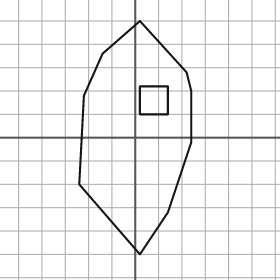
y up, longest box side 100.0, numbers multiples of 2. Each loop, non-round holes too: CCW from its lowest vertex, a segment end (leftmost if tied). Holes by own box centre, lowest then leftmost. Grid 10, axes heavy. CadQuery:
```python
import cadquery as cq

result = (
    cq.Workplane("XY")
    .moveTo(2.0, -50.0)
    .lineTo(14.0, -32.0)
    .lineTo(24.0, -2.0)
    .lineTo(24.0, 20.0)
    .lineTo(22.0, 28.0)
    .lineTo(2.0, 50.0)
    .lineTo(-14.0, 36.0)
    .lineTo(-22.0, 18.0)
    .lineTo(-24.0, -20.0)
    .close()
    .moveTo(2.0, 10.0)
    .lineTo(14.0, 10.0)
    .lineTo(14.0, 22.0)
    .lineTo(2.0, 22.0)
    .close()
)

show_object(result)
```